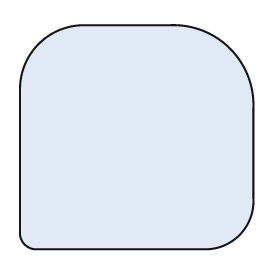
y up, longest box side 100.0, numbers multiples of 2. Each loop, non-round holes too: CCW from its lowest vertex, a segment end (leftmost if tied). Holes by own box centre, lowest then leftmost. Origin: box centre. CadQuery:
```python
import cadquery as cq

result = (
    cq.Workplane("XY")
    .moveTo(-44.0, -48.0)
    .lineTo(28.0, -48.0)
    .threePointArc((44.0, -42.0), (50.0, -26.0))
    .lineTo(50.0, 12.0)
    .threePointArc((40.0, 38.0), (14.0, 48.0))
    .lineTo(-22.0, 48.0)
    .threePointArc((-42.0, 40.0), (-50.0, 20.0))
    .lineTo(-50.0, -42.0)
    .threePointArc((-48.0, -46.0), (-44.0, -48.0))
    .close()
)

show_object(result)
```